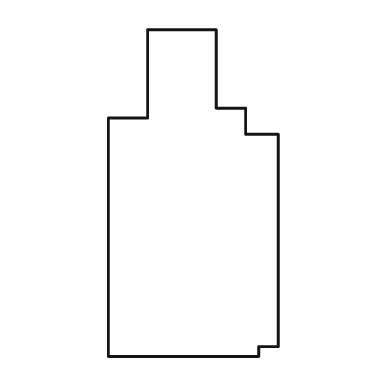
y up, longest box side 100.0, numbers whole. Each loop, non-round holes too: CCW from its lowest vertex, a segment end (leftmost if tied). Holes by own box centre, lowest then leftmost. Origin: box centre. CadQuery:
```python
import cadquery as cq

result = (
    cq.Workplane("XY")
    .moveTo(-26.0, -50.0)
    .lineTo(20.0, -50.0)
    .lineTo(20.0, -47.0)
    .lineTo(26.0, -47.0)
    .lineTo(26.0, 18.0)
    .lineTo(16.0, 18.0)
    .lineTo(16.0, 26.0)
    .lineTo(7.0, 26.0)
    .lineTo(7.0, 50.0)
    .lineTo(-14.0, 50.0)
    .lineTo(-14.0, 23.0)
    .lineTo(-26.0, 23.0)
    .close()
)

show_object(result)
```